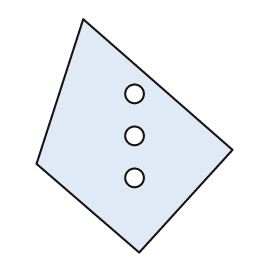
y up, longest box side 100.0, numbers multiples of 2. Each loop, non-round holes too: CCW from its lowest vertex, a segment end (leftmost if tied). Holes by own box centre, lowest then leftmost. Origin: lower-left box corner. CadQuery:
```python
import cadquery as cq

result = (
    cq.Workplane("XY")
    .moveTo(44.0, 0.0)
    .lineTo(84.0, 44.0)
    .lineTo(20.0, 100.0)
    .lineTo(0.0, 38.0)
    .close()
    .moveTo(42.0, 32.0)
    .circle(4.0)
    .moveTo(42.0, 50.0)
    .circle(4.0)
    .moveTo(42.0, 68.0)
    .circle(4.0)
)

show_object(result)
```